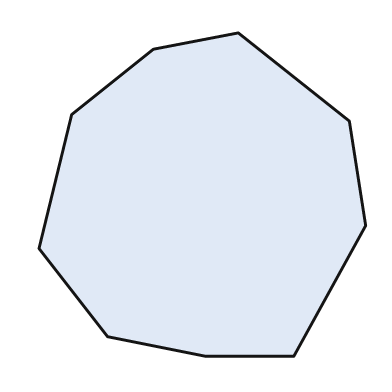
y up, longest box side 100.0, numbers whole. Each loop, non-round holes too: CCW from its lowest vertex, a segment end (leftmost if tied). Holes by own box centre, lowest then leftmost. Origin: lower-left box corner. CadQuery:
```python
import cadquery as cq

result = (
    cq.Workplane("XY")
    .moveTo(51.0, 0.0)
    .lineTo(78.0, 0.0)
    .lineTo(100.0, 40.0)
    .lineTo(95.0, 72.0)
    .lineTo(61.0, 99.0)
    .lineTo(35.0, 94.0)
    .lineTo(10.0, 74.0)
    .lineTo(0.0, 33.0)
    .lineTo(21.0, 6.0)
    .close()
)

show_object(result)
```